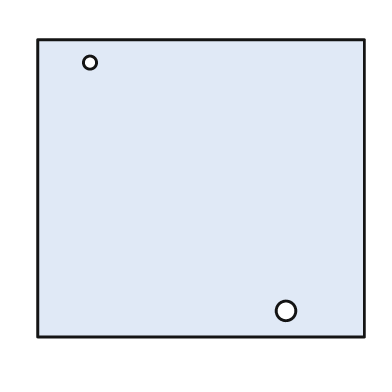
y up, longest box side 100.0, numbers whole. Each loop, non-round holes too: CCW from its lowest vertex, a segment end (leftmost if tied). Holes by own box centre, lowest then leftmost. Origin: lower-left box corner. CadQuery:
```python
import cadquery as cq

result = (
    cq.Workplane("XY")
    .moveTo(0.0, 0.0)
    .lineTo(100.0, 0.0)
    .lineTo(100.0, 91.0)
    .lineTo(0.0, 91.0)
    .close()
    .moveTo(76.0, 8.0)
    .circle(3.0)
    .moveTo(16.0, 84.0)
    .circle(2.0)
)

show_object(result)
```